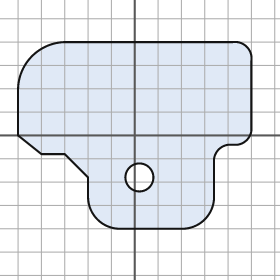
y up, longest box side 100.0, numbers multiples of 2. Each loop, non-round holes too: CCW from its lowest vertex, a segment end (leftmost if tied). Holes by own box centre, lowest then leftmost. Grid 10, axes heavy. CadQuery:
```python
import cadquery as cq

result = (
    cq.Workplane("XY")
    .moveTo(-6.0, -40.0)
    .lineTo(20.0, -40.0)
    .threePointArc((30.0, -36.0), (34.0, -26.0))
    .lineTo(34.0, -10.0)
    .threePointArc((36.0, -6.0), (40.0, -4.0))
    .lineTo(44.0, -4.0)
    .threePointArc((48.0, -2.0), (50.0, 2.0))
    .lineTo(50.0, 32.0)
    .threePointArc((48.0, 38.0), (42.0, 40.0))
    .lineTo(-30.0, 40.0)
    .threePointArc((-44.0, 34.0), (-50.0, 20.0))
    .lineTo(-50.0, 0.0)
    .lineTo(-40.0, -8.0)
    .lineTo(-30.0, -8.0)
    .lineTo(-20.0, -18.0)
    .lineTo(-20.0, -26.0)
    .threePointArc((-16.0, -36.0), (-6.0, -40.0))
    .close()
    .moveTo(2.0, -18.0)
    .circle(6.0)
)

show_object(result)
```